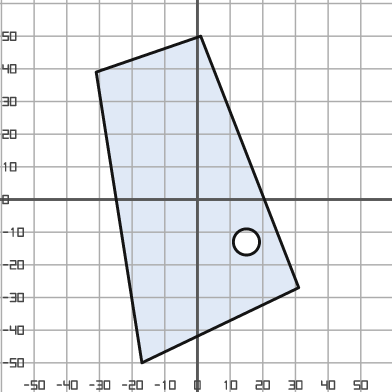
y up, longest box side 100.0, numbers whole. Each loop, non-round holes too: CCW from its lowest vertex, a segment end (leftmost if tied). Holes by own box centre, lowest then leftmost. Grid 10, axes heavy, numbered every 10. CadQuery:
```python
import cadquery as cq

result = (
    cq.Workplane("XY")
    .moveTo(-17.0, -50.0)
    .lineTo(31.0, -27.0)
    .lineTo(1.0, 50.0)
    .lineTo(-31.0, 39.0)
    .close()
    .moveTo(15.0, -13.0)
    .circle(4.0)
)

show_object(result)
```